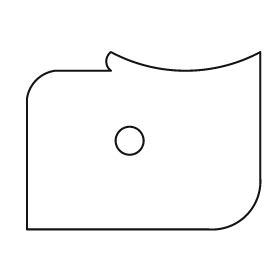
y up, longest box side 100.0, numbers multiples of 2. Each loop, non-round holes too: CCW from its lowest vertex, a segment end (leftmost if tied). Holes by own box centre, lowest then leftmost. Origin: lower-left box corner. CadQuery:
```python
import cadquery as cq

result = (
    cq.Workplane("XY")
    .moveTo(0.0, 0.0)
    .lineTo(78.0, 0.0)
    .threePointArc((94.0, 6.0), (100.0, 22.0))
    .lineTo(100.0, 76.0)
    .threePointArc((68.0, 68.0), (36.0, 76.0))
    .threePointArc((34.0, 72.0), (36.0, 68.0))
    .lineTo(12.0, 68.0)
    .threePointArc((4.0, 64.0), (0.0, 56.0))
    .close()
    .moveTo(44.0, 38.0)
    .circle(6.0)
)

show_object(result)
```